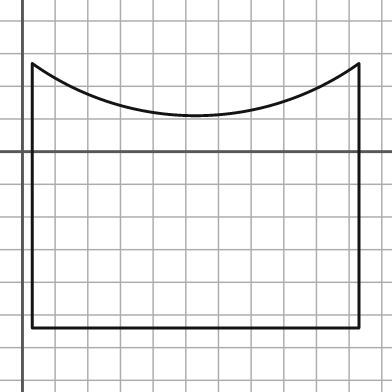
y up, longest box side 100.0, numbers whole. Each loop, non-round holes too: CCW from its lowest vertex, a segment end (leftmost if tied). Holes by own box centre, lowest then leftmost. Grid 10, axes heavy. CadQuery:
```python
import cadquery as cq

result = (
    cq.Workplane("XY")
    .moveTo(3.0, -54.0)
    .lineTo(103.0, -54.0)
    .lineTo(103.0, 27.0)
    .threePointArc((53.0, 11.0), (3.0, 27.0))
    .close()
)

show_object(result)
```